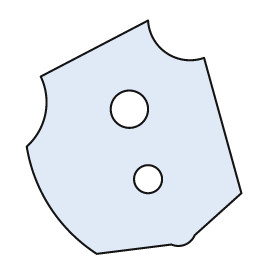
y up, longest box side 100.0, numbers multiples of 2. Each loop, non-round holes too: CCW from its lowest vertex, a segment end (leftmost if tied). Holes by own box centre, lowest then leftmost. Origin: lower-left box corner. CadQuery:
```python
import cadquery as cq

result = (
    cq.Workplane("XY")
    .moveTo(30.0, 0.0)
    .lineTo(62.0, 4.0)
    .threePointArc((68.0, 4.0), (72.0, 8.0))
    .lineTo(92.0, 26.0)
    .lineTo(76.0, 84.0)
    .threePointArc((60.0, 86.0), (52.0, 100.0))
    .lineTo(6.0, 76.0)
    .threePointArc((8.0, 60.0), (0.0, 46.0))
    .threePointArc((10.0, 20.0), (30.0, 0.0))
    .close()
    .moveTo(52.0, 32.0)
    .circle(6.0)
    .moveTo(44.0, 62.0)
    .circle(8.0)
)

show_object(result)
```